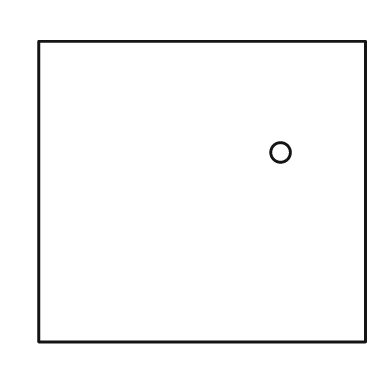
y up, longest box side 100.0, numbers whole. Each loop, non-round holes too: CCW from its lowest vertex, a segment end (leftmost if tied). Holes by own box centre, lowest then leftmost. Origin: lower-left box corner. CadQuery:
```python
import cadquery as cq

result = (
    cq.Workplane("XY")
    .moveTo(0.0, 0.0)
    .lineTo(100.0, 0.0)
    .lineTo(100.0, 92.0)
    .lineTo(0.0, 92.0)
    .close()
    .moveTo(74.0, 58.0)
    .circle(3.0)
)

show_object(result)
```